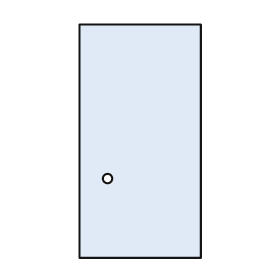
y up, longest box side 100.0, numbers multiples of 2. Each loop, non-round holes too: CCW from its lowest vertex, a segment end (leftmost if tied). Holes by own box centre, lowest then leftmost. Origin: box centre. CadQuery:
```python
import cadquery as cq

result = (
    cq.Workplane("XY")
    .moveTo(-26.0, -50.0)
    .lineTo(26.0, -50.0)
    .lineTo(26.0, 50.0)
    .lineTo(-26.0, 50.0)
    .close()
    .moveTo(-14.0, -16.0)
    .circle(2.0)
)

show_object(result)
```